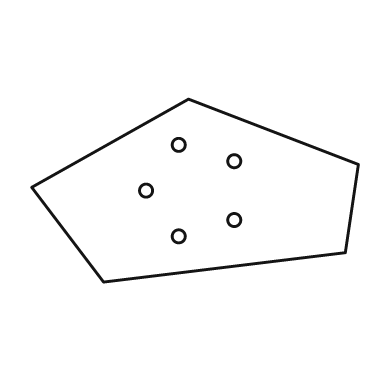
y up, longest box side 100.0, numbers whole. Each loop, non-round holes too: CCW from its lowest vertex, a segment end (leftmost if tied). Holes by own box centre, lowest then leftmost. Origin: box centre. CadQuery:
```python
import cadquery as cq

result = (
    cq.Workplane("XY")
    .moveTo(-28.0, -28.0)
    .lineTo(46.0, -19.0)
    .lineTo(50.0, 8.0)
    .lineTo(-2.0, 28.0)
    .lineTo(-50.0, 1.0)
    .close()
    .moveTo(-5.0, -14.0)
    .circle(2.0)
    .moveTo(12.0, -9.0)
    .circle(2.0)
    .moveTo(-15.0, 0.0)
    .circle(2.0)
    .moveTo(12.0, 9.0)
    .circle(2.0)
    .moveTo(-5.0, 14.0)
    .circle(2.0)
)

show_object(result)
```